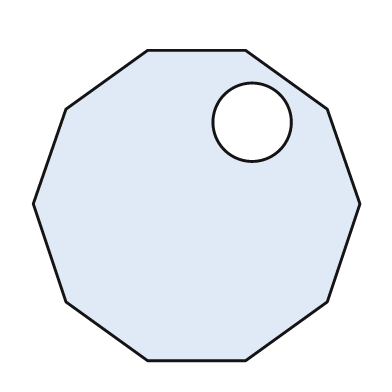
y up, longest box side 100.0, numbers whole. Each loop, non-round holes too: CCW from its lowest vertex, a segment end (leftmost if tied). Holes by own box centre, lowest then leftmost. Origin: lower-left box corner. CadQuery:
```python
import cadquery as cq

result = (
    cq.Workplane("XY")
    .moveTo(35.0, 0.0)
    .lineTo(65.0, 0.0)
    .lineTo(90.0, 18.0)
    .lineTo(100.0, 48.0)
    .lineTo(90.0, 77.0)
    .lineTo(65.0, 95.0)
    .lineTo(35.0, 95.0)
    .lineTo(10.0, 77.0)
    .lineTo(0.0, 48.0)
    .lineTo(10.0, 18.0)
    .close()
    .moveTo(67.0, 73.0)
    .circle(12.0)
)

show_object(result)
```